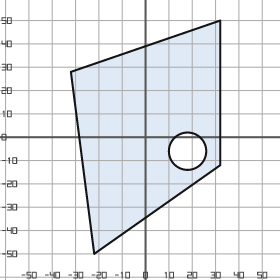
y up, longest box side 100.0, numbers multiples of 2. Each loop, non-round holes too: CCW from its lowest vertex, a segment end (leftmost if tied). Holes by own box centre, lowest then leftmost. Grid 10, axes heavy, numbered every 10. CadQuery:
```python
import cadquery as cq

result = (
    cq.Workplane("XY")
    .moveTo(-22.0, -50.0)
    .lineTo(32.0, -12.0)
    .lineTo(32.0, 50.0)
    .lineTo(-32.0, 28.0)
    .close()
    .moveTo(18.0, -6.0)
    .circle(8.0)
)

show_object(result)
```